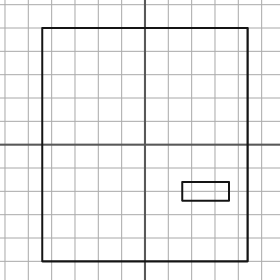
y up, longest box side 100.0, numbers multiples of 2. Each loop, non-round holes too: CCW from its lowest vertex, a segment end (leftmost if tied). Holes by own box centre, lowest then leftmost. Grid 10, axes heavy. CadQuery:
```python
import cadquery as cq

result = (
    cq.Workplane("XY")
    .moveTo(-44.0, -50.0)
    .lineTo(44.0, -50.0)
    .lineTo(44.0, 50.0)
    .lineTo(-44.0, 50.0)
    .close()
    .moveTo(16.0, -24.0)
    .lineTo(36.0, -24.0)
    .lineTo(36.0, -16.0)
    .lineTo(16.0, -16.0)
    .close()
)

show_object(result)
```